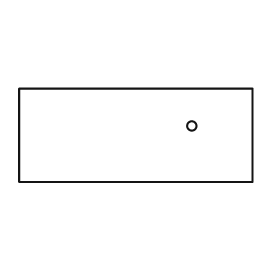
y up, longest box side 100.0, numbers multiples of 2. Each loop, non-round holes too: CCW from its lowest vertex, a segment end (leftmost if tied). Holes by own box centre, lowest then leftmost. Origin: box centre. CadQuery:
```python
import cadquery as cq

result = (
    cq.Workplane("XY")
    .moveTo(-50.0, -20.0)
    .lineTo(50.0, -20.0)
    .lineTo(50.0, 20.0)
    .lineTo(-50.0, 20.0)
    .close()
    .moveTo(24.0, 4.0)
    .circle(2.0)
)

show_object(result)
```